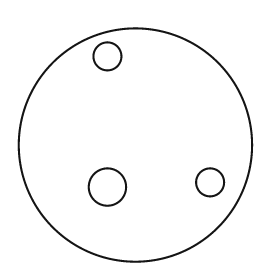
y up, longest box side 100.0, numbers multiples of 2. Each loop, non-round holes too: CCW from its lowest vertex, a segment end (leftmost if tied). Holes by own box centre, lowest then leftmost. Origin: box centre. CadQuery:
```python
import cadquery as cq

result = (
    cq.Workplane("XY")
    .moveTo(0.0, 0.0)
    .circle(50.0)
    .moveTo(-12.0, -18.0)
    .circle(8.0)
    .moveTo(32.0, -16.0)
    .circle(6.0)
    .moveTo(-12.0, 38.0)
    .circle(6.0)
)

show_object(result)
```